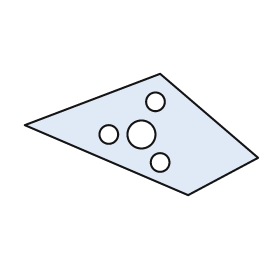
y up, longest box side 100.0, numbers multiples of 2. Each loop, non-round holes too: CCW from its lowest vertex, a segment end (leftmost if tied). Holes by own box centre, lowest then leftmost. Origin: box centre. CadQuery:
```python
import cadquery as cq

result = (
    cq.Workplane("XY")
    .moveTo(20.0, -26.0)
    .lineTo(50.0, -10.0)
    .lineTo(8.0, 26.0)
    .lineTo(-50.0, 4.0)
    .close()
    .moveTo(8.0, -12.0)
    .circle(4.0)
    .moveTo(-14.0, 0.0)
    .circle(4.0)
    .moveTo(0.0, 0.0)
    .circle(6.0)
    .moveTo(6.0, 14.0)
    .circle(4.0)
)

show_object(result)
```